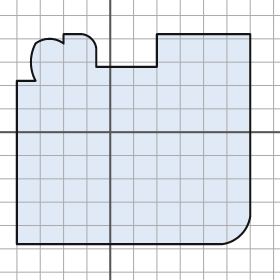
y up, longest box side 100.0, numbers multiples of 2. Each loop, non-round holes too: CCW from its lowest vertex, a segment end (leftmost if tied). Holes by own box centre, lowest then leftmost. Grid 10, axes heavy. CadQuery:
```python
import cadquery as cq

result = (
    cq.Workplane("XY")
    .moveTo(-40.0, -48.0)
    .lineTo(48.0, -48.0)
    .threePointArc((56.0, -44.0), (60.0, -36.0))
    .lineTo(60.0, 42.0)
    .lineTo(20.0, 42.0)
    .lineTo(20.0, 28.0)
    .lineTo(-6.0, 28.0)
    .lineTo(-6.0, 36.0)
    .threePointArc((-8.0, 40.0), (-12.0, 42.0))
    .lineTo(-20.0, 42.0)
    .lineTo(-20.0, 38.0)
    .threePointArc((-26.0, 40.0), (-32.0, 38.0))
    .threePointArc((-34.0, 30.0), (-32.0, 22.0))
    .lineTo(-40.0, 22.0)
    .close()
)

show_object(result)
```